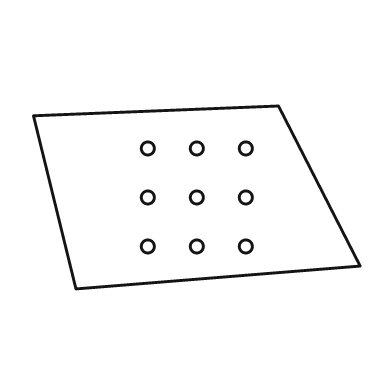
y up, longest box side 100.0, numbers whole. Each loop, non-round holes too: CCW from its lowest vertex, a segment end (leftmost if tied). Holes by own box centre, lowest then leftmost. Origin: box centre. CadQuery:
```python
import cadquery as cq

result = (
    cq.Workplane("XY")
    .moveTo(-37.0, -28.0)
    .lineTo(50.0, -21.0)
    .lineTo(25.0, 28.0)
    .lineTo(-50.0, 25.0)
    .close()
    .moveTo(-15.0, -15.0)
    .circle(2.0)
    .moveTo(0.0, -15.0)
    .circle(2.0)
    .moveTo(15.0, -15.0)
    .circle(2.0)
    .moveTo(-15.0, 0.0)
    .circle(2.0)
    .moveTo(0.0, 0.0)
    .circle(2.0)
    .moveTo(15.0, 0.0)
    .circle(2.0)
    .moveTo(-15.0, 15.0)
    .circle(2.0)
    .moveTo(0.0, 15.0)
    .circle(2.0)
    .moveTo(15.0, 15.0)
    .circle(2.0)
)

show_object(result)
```